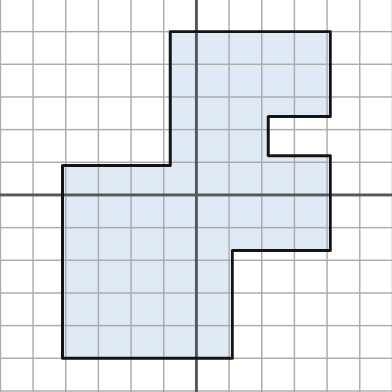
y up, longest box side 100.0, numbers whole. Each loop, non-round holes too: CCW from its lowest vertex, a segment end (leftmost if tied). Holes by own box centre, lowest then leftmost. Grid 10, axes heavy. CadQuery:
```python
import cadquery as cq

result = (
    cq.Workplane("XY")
    .moveTo(-41.0, -50.0)
    .lineTo(11.0, -50.0)
    .lineTo(11.0, -17.0)
    .lineTo(41.0, -17.0)
    .lineTo(41.0, 12.0)
    .lineTo(22.0, 12.0)
    .lineTo(22.0, 24.0)
    .lineTo(41.0, 24.0)
    .lineTo(41.0, 50.0)
    .lineTo(-8.0, 50.0)
    .lineTo(-8.0, 9.0)
    .lineTo(-41.0, 9.0)
    .close()
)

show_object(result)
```